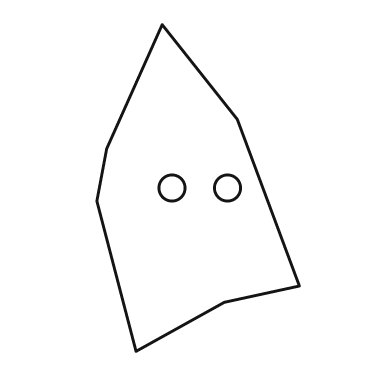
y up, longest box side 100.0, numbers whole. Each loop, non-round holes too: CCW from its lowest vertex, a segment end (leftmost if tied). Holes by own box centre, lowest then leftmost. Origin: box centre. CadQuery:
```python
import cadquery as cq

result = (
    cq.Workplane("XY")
    .moveTo(-19.0, -50.0)
    .lineTo(8.0, -35.0)
    .lineTo(31.0, -30.0)
    .lineTo(12.0, 21.0)
    .lineTo(-11.0, 50.0)
    .lineTo(-28.0, 12.0)
    .lineTo(-31.0, -4.0)
    .close()
    .moveTo(-8.0, 0.0)
    .circle(4.0)
    .moveTo(9.0, 0.0)
    .circle(4.0)
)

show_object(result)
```